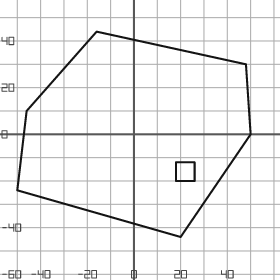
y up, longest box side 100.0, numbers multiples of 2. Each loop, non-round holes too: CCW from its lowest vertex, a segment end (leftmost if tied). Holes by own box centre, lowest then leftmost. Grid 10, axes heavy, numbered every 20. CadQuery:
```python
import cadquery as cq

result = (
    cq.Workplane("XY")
    .moveTo(20.0, -44.0)
    .lineTo(50.0, 0.0)
    .lineTo(48.0, 30.0)
    .lineTo(-16.0, 44.0)
    .lineTo(-46.0, 10.0)
    .lineTo(-50.0, -24.0)
    .close()
    .moveTo(18.0, -20.0)
    .lineTo(26.0, -20.0)
    .lineTo(26.0, -12.0)
    .lineTo(18.0, -12.0)
    .close()
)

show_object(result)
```